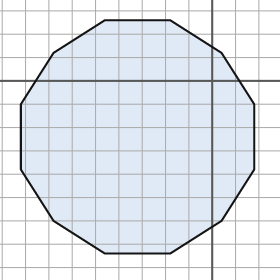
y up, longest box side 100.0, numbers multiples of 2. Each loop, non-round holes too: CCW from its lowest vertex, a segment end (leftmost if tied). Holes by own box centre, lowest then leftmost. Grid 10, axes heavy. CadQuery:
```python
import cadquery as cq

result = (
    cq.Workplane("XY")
    .moveTo(-46.0, -74.0)
    .lineTo(-18.0, -74.0)
    .lineTo(4.0, -60.0)
    .lineTo(18.0, -38.0)
    .lineTo(18.0, -10.0)
    .lineTo(4.0, 12.0)
    .lineTo(-18.0, 26.0)
    .lineTo(-46.0, 26.0)
    .lineTo(-68.0, 12.0)
    .lineTo(-82.0, -10.0)
    .lineTo(-82.0, -38.0)
    .lineTo(-68.0, -60.0)
    .close()
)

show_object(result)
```